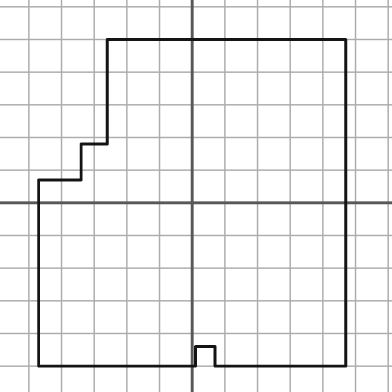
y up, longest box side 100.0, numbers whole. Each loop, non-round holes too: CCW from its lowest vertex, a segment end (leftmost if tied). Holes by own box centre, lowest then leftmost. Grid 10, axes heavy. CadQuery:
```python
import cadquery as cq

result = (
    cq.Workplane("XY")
    .moveTo(-47.0, -50.0)
    .lineTo(1.0, -50.0)
    .lineTo(1.0, -44.0)
    .lineTo(7.0, -44.0)
    .lineTo(7.0, -50.0)
    .lineTo(47.0, -50.0)
    .lineTo(47.0, 50.0)
    .lineTo(-26.0, 50.0)
    .lineTo(-26.0, 18.0)
    .lineTo(-34.0, 18.0)
    .lineTo(-34.0, 7.0)
    .lineTo(-47.0, 7.0)
    .close()
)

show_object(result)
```